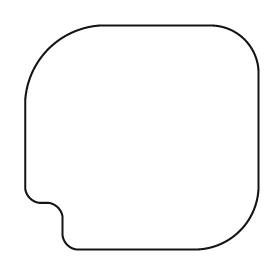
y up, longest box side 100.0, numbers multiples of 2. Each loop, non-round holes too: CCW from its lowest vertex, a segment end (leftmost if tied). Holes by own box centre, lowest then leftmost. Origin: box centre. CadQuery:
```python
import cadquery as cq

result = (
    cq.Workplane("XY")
    .moveTo(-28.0, -48.0)
    .lineTo(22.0, -48.0)
    .threePointArc((42.0, -40.0), (50.0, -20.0))
    .lineTo(50.0, 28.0)
    .threePointArc((44.0, 42.0), (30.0, 48.0))
    .lineTo(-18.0, 48.0)
    .threePointArc((-40.0, 38.0), (-50.0, 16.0))
    .lineTo(-50.0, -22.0)
    .threePointArc((-48.0, -26.0), (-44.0, -28.0))
    .lineTo(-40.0, -28.0)
    .threePointArc((-36.0, -30.0), (-34.0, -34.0))
    .lineTo(-34.0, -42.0)
    .threePointArc((-32.0, -46.0), (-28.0, -48.0))
    .close()
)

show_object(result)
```